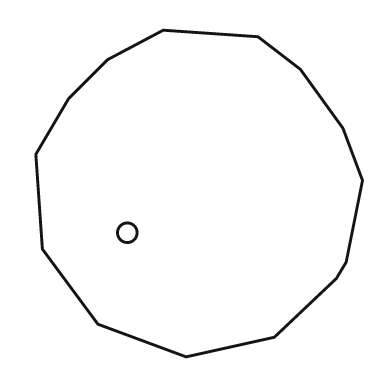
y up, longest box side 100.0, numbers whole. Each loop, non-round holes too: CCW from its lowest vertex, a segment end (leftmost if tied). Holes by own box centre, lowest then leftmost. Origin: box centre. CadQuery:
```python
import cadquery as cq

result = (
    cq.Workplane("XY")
    .moveTo(-4.0, -50.0)
    .lineTo(23.0, -44.0)
    .lineTo(42.0, -26.0)
    .lineTo(45.0, -21.0)
    .lineTo(50.0, 4.0)
    .lineTo(44.0, 20.0)
    .lineTo(31.0, 38.0)
    .lineTo(18.0, 48.0)
    .lineTo(-11.0, 50.0)
    .lineTo(-28.0, 41.0)
    .lineTo(-40.0, 29.0)
    .lineTo(-50.0, 12.0)
    .lineTo(-48.0, -17.0)
    .lineTo(-31.0, -40.0)
    .close()
    .moveTo(-22.0, -12.0)
    .circle(3.0)
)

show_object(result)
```